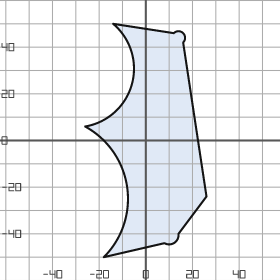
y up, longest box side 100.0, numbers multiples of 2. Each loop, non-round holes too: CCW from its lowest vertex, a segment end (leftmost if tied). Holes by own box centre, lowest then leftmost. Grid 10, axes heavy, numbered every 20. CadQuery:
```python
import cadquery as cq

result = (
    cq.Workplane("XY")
    .moveTo(-18.0, -50.0)
    .lineTo(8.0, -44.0)
    .threePointArc((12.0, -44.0), (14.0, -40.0))
    .lineTo(26.0, -24.0)
    .lineTo(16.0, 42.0)
    .threePointArc((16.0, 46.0), (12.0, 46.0))
    .lineTo(-14.0, 50.0)
    .threePointArc((-6.0, 24.0), (-26.0, 6.0))
    .threePointArc((-8.0, -20.0), (-18.0, -50.0))
    .close()
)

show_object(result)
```